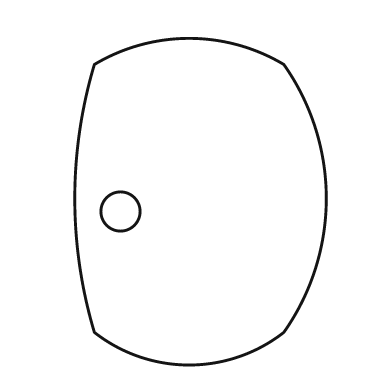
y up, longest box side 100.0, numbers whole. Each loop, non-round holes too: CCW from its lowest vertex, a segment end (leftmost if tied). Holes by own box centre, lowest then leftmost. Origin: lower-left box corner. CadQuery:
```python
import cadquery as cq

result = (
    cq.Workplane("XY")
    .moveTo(6.0, 10.0)
    .threePointArc((35.0, 0.0), (64.0, 10.0))
    .threePointArc((77.0, 51.0), (64.0, 92.0))
    .threePointArc((35.0, 100.0), (6.0, 92.0))
    .threePointArc((0.0, 51.0), (6.0, 10.0))
    .close()
    .moveTo(14.0, 47.0)
    .circle(6.0)
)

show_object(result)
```